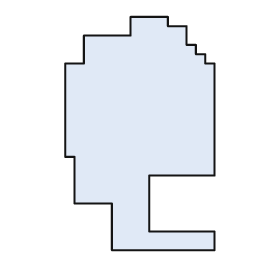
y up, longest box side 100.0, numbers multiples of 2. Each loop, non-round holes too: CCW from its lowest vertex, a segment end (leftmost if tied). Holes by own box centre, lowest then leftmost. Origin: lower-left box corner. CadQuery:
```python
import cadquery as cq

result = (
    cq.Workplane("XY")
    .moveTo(20.0, 0.0)
    .lineTo(64.0, 0.0)
    .lineTo(64.0, 8.0)
    .lineTo(36.0, 8.0)
    .lineTo(36.0, 32.0)
    .lineTo(64.0, 32.0)
    .lineTo(64.0, 80.0)
    .lineTo(60.0, 80.0)
    .lineTo(60.0, 84.0)
    .lineTo(56.0, 84.0)
    .lineTo(56.0, 88.0)
    .lineTo(52.0, 88.0)
    .lineTo(52.0, 96.0)
    .lineTo(44.0, 96.0)
    .lineTo(44.0, 100.0)
    .lineTo(28.0, 100.0)
    .lineTo(28.0, 92.0)
    .lineTo(8.0, 92.0)
    .lineTo(8.0, 80.0)
    .lineTo(0.0, 80.0)
    .lineTo(0.0, 40.0)
    .lineTo(4.0, 40.0)
    .lineTo(4.0, 20.0)
    .lineTo(20.0, 20.0)
    .close()
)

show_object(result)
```